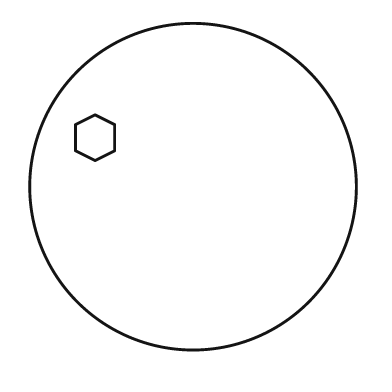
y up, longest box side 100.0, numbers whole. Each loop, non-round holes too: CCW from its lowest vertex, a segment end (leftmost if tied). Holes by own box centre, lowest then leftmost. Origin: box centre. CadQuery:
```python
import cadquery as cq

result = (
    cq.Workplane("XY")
    .moveTo(0.0, 0.0)
    .circle(50.0)
    .moveTo(-30.0, 8.0)
    .lineTo(-24.0, 11.0)
    .lineTo(-24.0, 19.0)
    .lineTo(-30.0, 22.0)
    .lineTo(-36.0, 19.0)
    .lineTo(-36.0, 11.0)
    .close()
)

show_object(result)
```